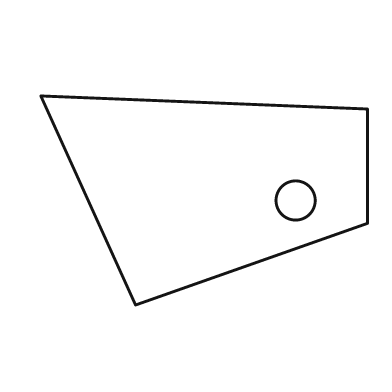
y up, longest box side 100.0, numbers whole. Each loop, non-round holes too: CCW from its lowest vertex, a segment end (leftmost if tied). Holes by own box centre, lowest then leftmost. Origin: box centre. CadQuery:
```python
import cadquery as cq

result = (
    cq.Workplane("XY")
    .moveTo(-21.0, -32.0)
    .lineTo(50.0, -7.0)
    .lineTo(50.0, 28.0)
    .lineTo(-50.0, 32.0)
    .close()
    .moveTo(28.0, 0.0)
    .circle(6.0)
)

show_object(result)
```